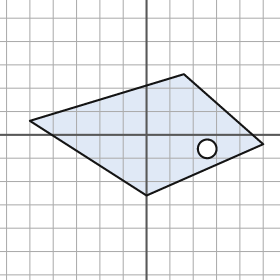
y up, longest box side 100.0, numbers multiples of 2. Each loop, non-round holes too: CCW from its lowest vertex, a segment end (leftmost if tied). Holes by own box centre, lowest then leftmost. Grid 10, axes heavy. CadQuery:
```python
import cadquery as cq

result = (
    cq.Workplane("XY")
    .moveTo(0.0, -26.0)
    .lineTo(50.0, -4.0)
    .lineTo(16.0, 26.0)
    .lineTo(-50.0, 6.0)
    .close()
    .moveTo(26.0, -6.0)
    .circle(4.0)
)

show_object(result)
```